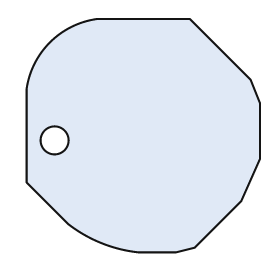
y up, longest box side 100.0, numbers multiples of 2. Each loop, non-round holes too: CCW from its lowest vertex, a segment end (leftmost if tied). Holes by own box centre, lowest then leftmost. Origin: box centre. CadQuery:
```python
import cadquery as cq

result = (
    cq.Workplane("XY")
    .moveTo(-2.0, -50.0)
    .lineTo(14.0, -50.0)
    .lineTo(22.0, -48.0)
    .lineTo(42.0, -28.0)
    .lineTo(50.0, -10.0)
    .lineTo(50.0, 14.0)
    .lineTo(46.0, 24.0)
    .lineTo(20.0, 50.0)
    .lineTo(-20.0, 50.0)
    .threePointArc((-40.0, 40.0), (-50.0, 20.0))
    .lineTo(-50.0, -20.0)
    .lineTo(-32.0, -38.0)
    .threePointArc((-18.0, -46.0), (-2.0, -50.0))
    .close()
    .moveTo(-38.0, -2.0)
    .circle(6.0)
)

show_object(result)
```